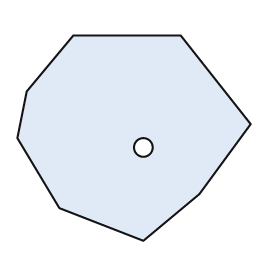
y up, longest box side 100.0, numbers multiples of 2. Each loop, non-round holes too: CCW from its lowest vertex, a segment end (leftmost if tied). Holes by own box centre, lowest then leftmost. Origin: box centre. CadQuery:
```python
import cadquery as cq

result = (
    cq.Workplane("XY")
    .moveTo(4.0, -44.0)
    .lineTo(28.0, -24.0)
    .lineTo(50.0, 6.0)
    .lineTo(20.0, 44.0)
    .lineTo(-26.0, 44.0)
    .lineTo(-46.0, 20.0)
    .lineTo(-50.0, 0.0)
    .lineTo(-32.0, -30.0)
    .close()
    .moveTo(4.0, -4.0)
    .circle(4.0)
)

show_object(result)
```